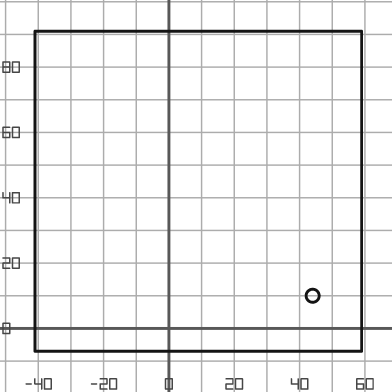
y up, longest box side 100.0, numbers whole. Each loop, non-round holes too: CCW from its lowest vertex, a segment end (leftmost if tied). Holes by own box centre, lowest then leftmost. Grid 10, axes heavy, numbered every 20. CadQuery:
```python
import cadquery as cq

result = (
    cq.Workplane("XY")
    .moveTo(-41.0, -7.0)
    .lineTo(59.0, -7.0)
    .lineTo(59.0, 91.0)
    .lineTo(-41.0, 91.0)
    .close()
    .moveTo(44.0, 10.0)
    .circle(2.0)
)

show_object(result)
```